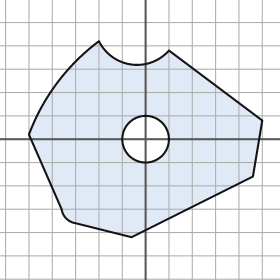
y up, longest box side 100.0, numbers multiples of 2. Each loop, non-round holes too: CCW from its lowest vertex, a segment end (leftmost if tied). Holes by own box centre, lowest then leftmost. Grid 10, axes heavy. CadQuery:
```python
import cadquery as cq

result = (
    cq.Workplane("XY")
    .moveTo(-6.0, -42.0)
    .lineTo(46.0, -16.0)
    .lineTo(50.0, 8.0)
    .lineTo(10.0, 38.0)
    .threePointArc((-6.0, 32.0), (-20.0, 42.0))
    .threePointArc((-38.0, 24.0), (-50.0, 2.0))
    .lineTo(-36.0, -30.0)
    .threePointArc((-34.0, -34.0), (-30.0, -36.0))
    .close()
    .moveTo(0.0, 0.0)
    .circle(10.0)
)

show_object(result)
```